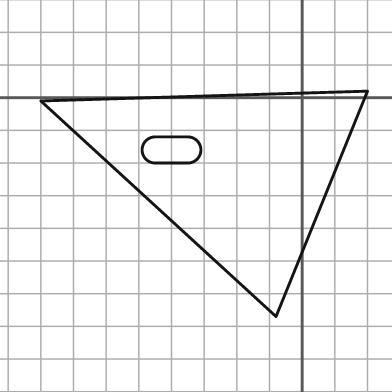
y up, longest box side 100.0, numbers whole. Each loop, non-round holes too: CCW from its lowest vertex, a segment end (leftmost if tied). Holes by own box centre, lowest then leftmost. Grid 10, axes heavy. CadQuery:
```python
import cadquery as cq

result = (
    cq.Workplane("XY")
    .moveTo(-8.0, -67.0)
    .lineTo(20.0, 2.0)
    .lineTo(-80.0, -1.0)
    .close()
    .moveTo(-45.0, -20.0)
    .lineTo(-35.0, -20.0)
    .threePointArc((-31.0, -16.0), (-35.0, -12.0))
    .lineTo(-45.0, -12.0)
    .threePointArc((-49.0, -16.0), (-45.0, -20.0))
    .close()
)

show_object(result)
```